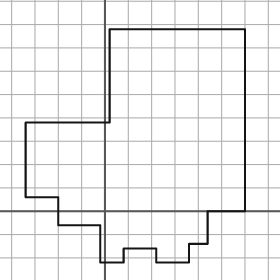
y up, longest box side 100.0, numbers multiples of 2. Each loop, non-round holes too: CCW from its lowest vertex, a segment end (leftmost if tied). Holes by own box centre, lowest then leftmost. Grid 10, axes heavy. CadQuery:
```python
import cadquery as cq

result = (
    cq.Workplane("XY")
    .moveTo(-2.0, -22.0)
    .lineTo(8.0, -22.0)
    .lineTo(8.0, -16.0)
    .lineTo(22.0, -16.0)
    .lineTo(22.0, -22.0)
    .lineTo(36.0, -22.0)
    .lineTo(36.0, -14.0)
    .lineTo(44.0, -14.0)
    .lineTo(44.0, 0.0)
    .lineTo(60.0, 0.0)
    .lineTo(60.0, 78.0)
    .lineTo(2.0, 78.0)
    .lineTo(2.0, 38.0)
    .lineTo(-34.0, 38.0)
    .lineTo(-34.0, 6.0)
    .lineTo(-20.0, 6.0)
    .lineTo(-20.0, -6.0)
    .lineTo(-2.0, -6.0)
    .close()
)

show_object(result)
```